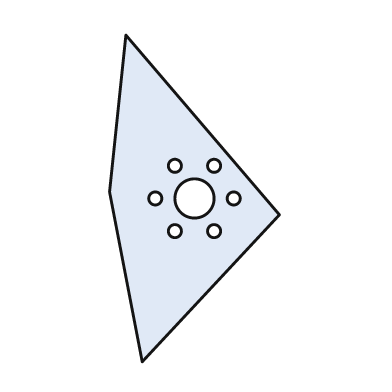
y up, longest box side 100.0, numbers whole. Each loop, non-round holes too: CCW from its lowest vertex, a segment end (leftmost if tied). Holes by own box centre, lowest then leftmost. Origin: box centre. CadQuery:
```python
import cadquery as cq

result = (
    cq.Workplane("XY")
    .moveTo(-16.0, -50.0)
    .lineTo(26.0, -5.0)
    .lineTo(-21.0, 50.0)
    .lineTo(-26.0, 2.0)
    .close()
    .moveTo(-6.0, -10.0)
    .circle(2.0)
    .moveTo(6.0, -10.0)
    .circle(2.0)
    .moveTo(-12.0, 0.0)
    .circle(2.0)
    .moveTo(0.0, 0.0)
    .circle(6.0)
    .moveTo(12.0, 0.0)
    .circle(2.0)
    .moveTo(-6.0, 10.0)
    .circle(2.0)
    .moveTo(6.0, 10.0)
    .circle(2.0)
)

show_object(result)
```